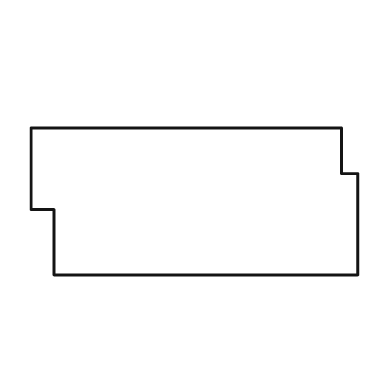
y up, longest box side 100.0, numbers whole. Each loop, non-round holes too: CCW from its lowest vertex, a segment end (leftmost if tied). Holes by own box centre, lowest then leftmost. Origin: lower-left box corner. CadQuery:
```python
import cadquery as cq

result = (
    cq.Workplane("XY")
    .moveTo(7.0, 0.0)
    .lineTo(100.0, 0.0)
    .lineTo(100.0, 31.0)
    .lineTo(95.0, 31.0)
    .lineTo(95.0, 45.0)
    .lineTo(0.0, 45.0)
    .lineTo(0.0, 20.0)
    .lineTo(7.0, 20.0)
    .close()
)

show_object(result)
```